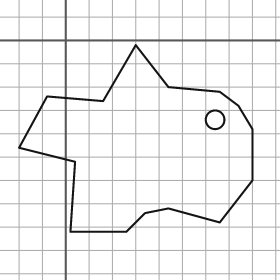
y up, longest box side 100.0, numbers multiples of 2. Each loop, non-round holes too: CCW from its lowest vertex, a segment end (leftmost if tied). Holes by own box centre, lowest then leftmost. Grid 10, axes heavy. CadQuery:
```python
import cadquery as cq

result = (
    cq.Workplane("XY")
    .moveTo(2.0, -82.0)
    .lineTo(26.0, -82.0)
    .lineTo(34.0, -74.0)
    .lineTo(44.0, -72.0)
    .lineTo(66.0, -78.0)
    .lineTo(80.0, -60.0)
    .lineTo(80.0, -38.0)
    .lineTo(74.0, -28.0)
    .lineTo(66.0, -22.0)
    .lineTo(44.0, -20.0)
    .lineTo(30.0, -2.0)
    .lineTo(16.0, -26.0)
    .lineTo(-8.0, -24.0)
    .lineTo(-20.0, -46.0)
    .lineTo(4.0, -52.0)
    .close()
    .moveTo(64.0, -34.0)
    .circle(4.0)
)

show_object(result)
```